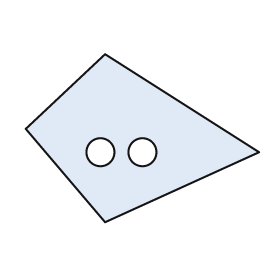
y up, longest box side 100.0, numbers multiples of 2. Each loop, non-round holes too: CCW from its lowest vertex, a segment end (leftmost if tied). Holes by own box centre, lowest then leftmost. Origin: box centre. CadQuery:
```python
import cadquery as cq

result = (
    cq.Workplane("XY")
    .moveTo(-16.0, -36.0)
    .lineTo(50.0, -6.0)
    .lineTo(-16.0, 36.0)
    .lineTo(-50.0, 4.0)
    .close()
    .moveTo(-18.0, -6.0)
    .circle(6.0)
    .moveTo(0.0, -6.0)
    .circle(6.0)
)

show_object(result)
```